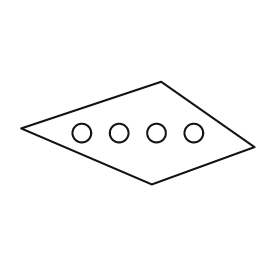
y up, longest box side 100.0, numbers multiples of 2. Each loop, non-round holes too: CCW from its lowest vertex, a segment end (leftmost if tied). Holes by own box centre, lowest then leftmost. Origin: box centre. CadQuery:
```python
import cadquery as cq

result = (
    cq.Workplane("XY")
    .moveTo(6.0, -22.0)
    .lineTo(50.0, -6.0)
    .lineTo(10.0, 22.0)
    .lineTo(-50.0, 2.0)
    .close()
    .moveTo(-24.0, 0.0)
    .circle(4.0)
    .moveTo(-8.0, 0.0)
    .circle(4.0)
    .moveTo(8.0, 0.0)
    .circle(4.0)
    .moveTo(24.0, 0.0)
    .circle(4.0)
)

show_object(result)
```